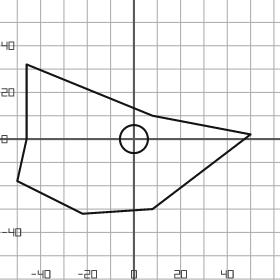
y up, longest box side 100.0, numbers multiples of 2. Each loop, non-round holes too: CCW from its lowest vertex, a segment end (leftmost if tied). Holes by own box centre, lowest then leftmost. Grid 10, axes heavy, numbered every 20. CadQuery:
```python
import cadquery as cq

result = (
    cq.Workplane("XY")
    .moveTo(-22.0, -32.0)
    .lineTo(8.0, -30.0)
    .lineTo(50.0, 2.0)
    .lineTo(8.0, 10.0)
    .lineTo(-46.0, 32.0)
    .lineTo(-46.0, 0.0)
    .lineTo(-50.0, -18.0)
    .close()
    .moveTo(0.0, 0.0)
    .circle(6.0)
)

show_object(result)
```